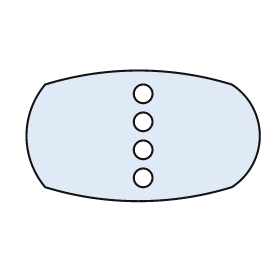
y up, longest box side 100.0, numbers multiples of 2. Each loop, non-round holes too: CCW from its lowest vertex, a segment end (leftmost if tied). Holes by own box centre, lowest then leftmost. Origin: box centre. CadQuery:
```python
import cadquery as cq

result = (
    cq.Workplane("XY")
    .moveTo(-42.0, -22.0)
    .threePointArc((-2.0, -28.0), (38.0, -22.0))
    .threePointArc((50.0, 0.0), (38.0, 22.0))
    .threePointArc((-2.0, 28.0), (-42.0, 22.0))
    .threePointArc((-50.0, 0.0), (-42.0, -22.0))
    .close()
    .moveTo(0.0, -18.0)
    .circle(4.0)
    .moveTo(0.0, -6.0)
    .circle(4.0)
    .moveTo(0.0, 6.0)
    .circle(4.0)
    .moveTo(0.0, 18.0)
    .circle(4.0)
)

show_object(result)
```